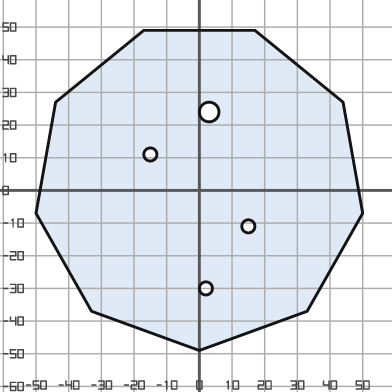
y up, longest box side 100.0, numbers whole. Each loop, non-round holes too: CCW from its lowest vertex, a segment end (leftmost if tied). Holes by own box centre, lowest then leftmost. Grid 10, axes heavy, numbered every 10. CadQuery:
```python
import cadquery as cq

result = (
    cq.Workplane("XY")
    .moveTo(0.0, -49.0)
    .lineTo(33.0, -37.0)
    .lineTo(50.0, -7.0)
    .lineTo(44.0, 27.0)
    .lineTo(17.0, 49.0)
    .lineTo(-17.0, 49.0)
    .lineTo(-44.0, 27.0)
    .lineTo(-50.0, -7.0)
    .lineTo(-33.0, -37.0)
    .close()
    .moveTo(2.0, -30.0)
    .circle(2.0)
    .moveTo(15.0, -11.0)
    .circle(2.0)
    .moveTo(-15.0, 11.0)
    .circle(2.0)
    .moveTo(3.0, 24.0)
    .circle(3.0)
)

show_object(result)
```